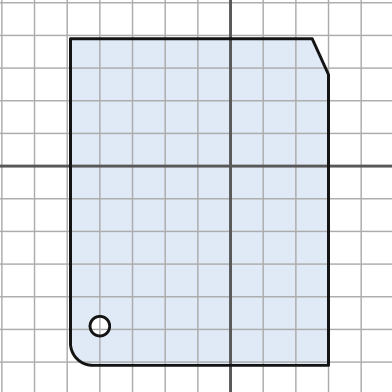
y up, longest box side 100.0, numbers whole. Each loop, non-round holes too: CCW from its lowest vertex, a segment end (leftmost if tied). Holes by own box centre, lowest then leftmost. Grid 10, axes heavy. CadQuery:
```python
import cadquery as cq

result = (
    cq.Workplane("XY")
    .moveTo(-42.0, -61.0)
    .lineTo(30.0, -61.0)
    .lineTo(30.0, 28.0)
    .lineTo(25.0, 39.0)
    .lineTo(-49.0, 39.0)
    .lineTo(-49.0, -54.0)
    .threePointArc((-47.0, -59.0), (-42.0, -61.0))
    .close()
    .moveTo(-40.0, -49.0)
    .circle(3.0)
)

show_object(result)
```